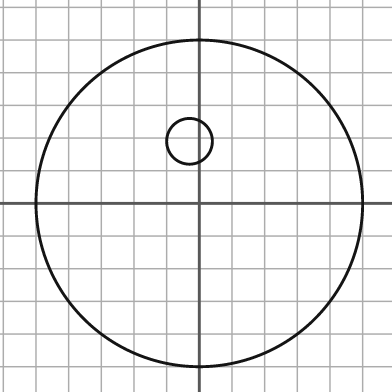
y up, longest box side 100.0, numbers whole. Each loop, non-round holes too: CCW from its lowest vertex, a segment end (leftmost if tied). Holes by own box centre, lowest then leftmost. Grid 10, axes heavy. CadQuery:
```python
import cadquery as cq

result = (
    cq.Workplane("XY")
    .moveTo(0.0, 0.0)
    .circle(50.0)
    .moveTo(-3.0, 19.0)
    .circle(7.0)
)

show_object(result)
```